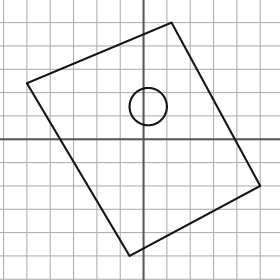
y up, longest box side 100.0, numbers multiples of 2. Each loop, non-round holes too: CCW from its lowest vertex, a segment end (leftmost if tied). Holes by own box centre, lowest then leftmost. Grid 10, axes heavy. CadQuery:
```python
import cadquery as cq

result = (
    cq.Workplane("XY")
    .moveTo(-6.0, -50.0)
    .lineTo(50.0, -20.0)
    .lineTo(12.0, 50.0)
    .lineTo(-50.0, 24.0)
    .close()
    .moveTo(2.0, 14.0)
    .circle(8.0)
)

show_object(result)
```